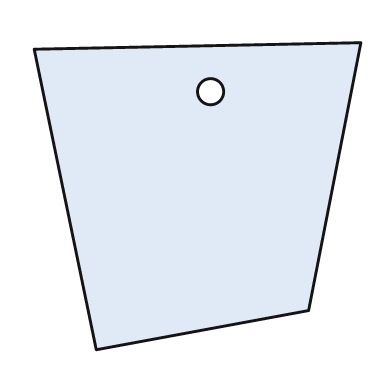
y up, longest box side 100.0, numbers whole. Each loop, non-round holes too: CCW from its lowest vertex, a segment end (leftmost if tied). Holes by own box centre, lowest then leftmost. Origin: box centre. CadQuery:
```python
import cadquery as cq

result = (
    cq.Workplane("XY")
    .moveTo(-31.0, -47.0)
    .lineTo(34.0, -35.0)
    .lineTo(50.0, 47.0)
    .lineTo(-50.0, 45.0)
    .close()
    .moveTo(4.0, 32.0)
    .circle(4.0)
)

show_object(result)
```